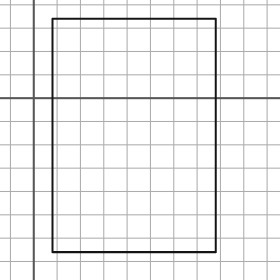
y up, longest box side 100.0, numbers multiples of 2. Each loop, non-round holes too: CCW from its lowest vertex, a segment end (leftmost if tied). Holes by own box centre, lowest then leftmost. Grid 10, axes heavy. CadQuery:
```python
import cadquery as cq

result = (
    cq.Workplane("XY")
    .moveTo(8.0, -66.0)
    .lineTo(78.0, -66.0)
    .lineTo(78.0, 34.0)
    .lineTo(8.0, 34.0)
    .close()
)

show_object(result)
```